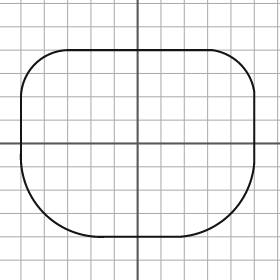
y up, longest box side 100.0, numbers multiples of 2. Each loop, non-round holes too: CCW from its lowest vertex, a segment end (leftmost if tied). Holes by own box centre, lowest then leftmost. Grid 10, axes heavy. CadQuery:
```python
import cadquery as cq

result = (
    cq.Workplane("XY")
    .moveTo(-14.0, -40.0)
    .lineTo(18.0, -40.0)
    .threePointArc((40.0, -30.0), (50.0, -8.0))
    .lineTo(50.0, 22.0)
    .threePointArc((44.0, 34.0), (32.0, 40.0))
    .lineTo(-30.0, 40.0)
    .threePointArc((-44.0, 34.0), (-50.0, 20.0))
    .lineTo(-50.0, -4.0)
    .threePointArc((-40.0, -30.0), (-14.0, -40.0))
    .close()
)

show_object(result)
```